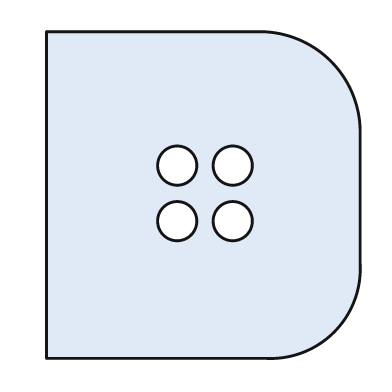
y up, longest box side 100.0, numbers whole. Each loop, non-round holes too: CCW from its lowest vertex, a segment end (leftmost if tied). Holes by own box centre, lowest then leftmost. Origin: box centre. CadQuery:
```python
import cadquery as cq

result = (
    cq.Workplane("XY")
    .moveTo(-48.0, -50.0)
    .lineTo(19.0, -50.0)
    .threePointArc((40.0, -42.0), (48.0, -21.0))
    .lineTo(48.0, 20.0)
    .threePointArc((39.0, 41.0), (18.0, 50.0))
    .lineTo(-48.0, 50.0)
    .close()
    .moveTo(-8.0, -8.0)
    .circle(6.0)
    .moveTo(9.0, -8.0)
    .circle(6.0)
    .moveTo(-8.0, 9.0)
    .circle(6.0)
    .moveTo(9.0, 9.0)
    .circle(6.0)
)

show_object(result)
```